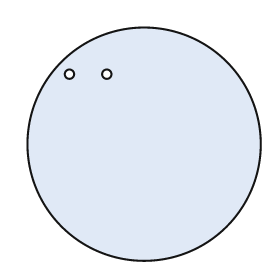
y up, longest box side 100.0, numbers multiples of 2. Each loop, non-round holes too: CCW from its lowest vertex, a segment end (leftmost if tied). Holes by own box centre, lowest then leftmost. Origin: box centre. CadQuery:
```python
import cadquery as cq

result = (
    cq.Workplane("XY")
    .moveTo(0.0, 0.0)
    .circle(50.0)
    .moveTo(-32.0, 30.0)
    .circle(2.0)
    .moveTo(-16.0, 30.0)
    .circle(2.0)
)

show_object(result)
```